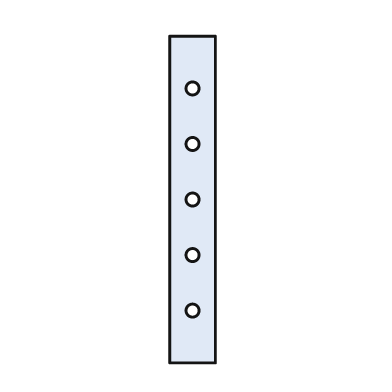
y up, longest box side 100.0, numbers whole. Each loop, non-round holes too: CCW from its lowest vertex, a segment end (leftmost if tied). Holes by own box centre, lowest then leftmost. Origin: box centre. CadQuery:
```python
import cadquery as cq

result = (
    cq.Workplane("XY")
    .moveTo(-7.0, -50.0)
    .lineTo(7.0, -50.0)
    .lineTo(7.0, 50.0)
    .lineTo(-7.0, 50.0)
    .close()
    .moveTo(0.0, -34.0)
    .circle(2.0)
    .moveTo(0.0, -17.0)
    .circle(2.0)
    .moveTo(0.0, 0.0)
    .circle(2.0)
    .moveTo(0.0, 17.0)
    .circle(2.0)
    .moveTo(0.0, 34.0)
    .circle(2.0)
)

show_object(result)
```